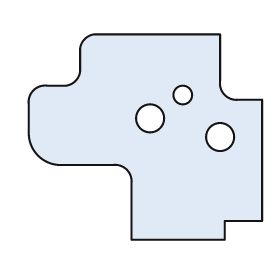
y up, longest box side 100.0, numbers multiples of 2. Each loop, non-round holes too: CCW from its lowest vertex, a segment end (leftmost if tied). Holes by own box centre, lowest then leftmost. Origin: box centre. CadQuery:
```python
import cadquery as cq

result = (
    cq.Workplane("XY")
    .moveTo(-6.0, -44.0)
    .lineTo(34.0, -44.0)
    .lineTo(34.0, -36.0)
    .lineTo(50.0, -36.0)
    .lineTo(50.0, 16.0)
    .lineTo(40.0, 16.0)
    .threePointArc((34.0, 18.0), (32.0, 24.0))
    .lineTo(32.0, 44.0)
    .lineTo(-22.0, 44.0)
    .threePointArc((-26.0, 42.0), (-28.0, 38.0))
    .lineTo(-28.0, 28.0)
    .threePointArc((-30.0, 24.0), (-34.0, 22.0))
    .lineTo(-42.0, 22.0)
    .threePointArc((-48.0, 20.0), (-50.0, 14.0))
    .lineTo(-50.0, 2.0)
    .threePointArc((-46.0, -8.0), (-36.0, -12.0))
    .lineTo(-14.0, -12.0)
    .threePointArc((-8.0, -14.0), (-6.0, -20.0))
    .close()
    .moveTo(32.0, 0.0)
    .circle(6.0)
    .moveTo(2.0, 8.0)
    .circle(6.0)
    .moveTo(16.0, 18.0)
    .circle(4.0)
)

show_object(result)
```